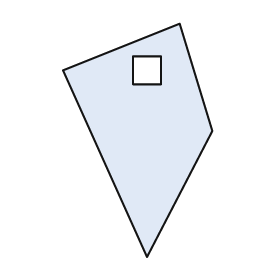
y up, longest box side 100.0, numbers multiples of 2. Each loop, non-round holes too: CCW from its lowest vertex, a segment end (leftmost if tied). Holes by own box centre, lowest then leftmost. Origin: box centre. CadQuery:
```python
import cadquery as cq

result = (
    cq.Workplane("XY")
    .moveTo(4.0, -50.0)
    .lineTo(32.0, 4.0)
    .lineTo(18.0, 50.0)
    .lineTo(-32.0, 30.0)
    .close()
    .moveTo(-2.0, 24.0)
    .lineTo(10.0, 24.0)
    .lineTo(10.0, 36.0)
    .lineTo(-2.0, 36.0)
    .close()
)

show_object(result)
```